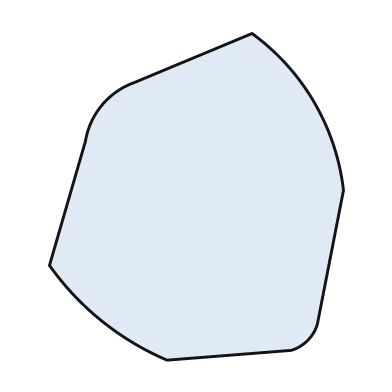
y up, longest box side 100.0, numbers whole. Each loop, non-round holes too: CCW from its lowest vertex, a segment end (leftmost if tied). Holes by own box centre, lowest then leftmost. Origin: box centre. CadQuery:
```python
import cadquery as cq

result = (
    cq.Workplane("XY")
    .moveTo(-9.0, -50.0)
    .lineTo(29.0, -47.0)
    .threePointArc((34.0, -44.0), (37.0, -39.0))
    .lineTo(45.0, 2.0)
    .threePointArc((36.0, 29.0), (17.0, 50.0))
    .lineTo(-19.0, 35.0)
    .threePointArc((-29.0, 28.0), (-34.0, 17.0))
    .lineTo(-45.0, -21.0)
    .threePointArc((-29.0, -38.0), (-9.0, -50.0))
    .close()
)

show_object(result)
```